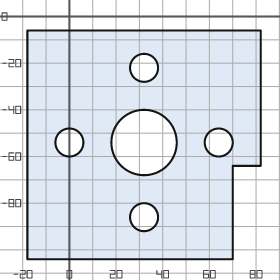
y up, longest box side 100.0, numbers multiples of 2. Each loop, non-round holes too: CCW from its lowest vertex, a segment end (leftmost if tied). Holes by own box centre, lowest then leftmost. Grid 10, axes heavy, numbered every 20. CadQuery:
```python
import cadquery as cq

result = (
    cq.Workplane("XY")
    .moveTo(-18.0, -104.0)
    .lineTo(70.0, -104.0)
    .lineTo(70.0, -64.0)
    .lineTo(82.0, -64.0)
    .lineTo(82.0, -6.0)
    .lineTo(-18.0, -6.0)
    .close()
    .moveTo(32.0, -86.0)
    .circle(6.0)
    .moveTo(0.0, -54.0)
    .circle(6.0)
    .moveTo(32.0, -54.0)
    .circle(14.0)
    .moveTo(64.0, -54.0)
    .circle(6.0)
    .moveTo(32.0, -22.0)
    .circle(6.0)
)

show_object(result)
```